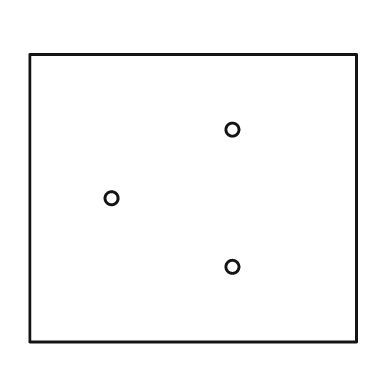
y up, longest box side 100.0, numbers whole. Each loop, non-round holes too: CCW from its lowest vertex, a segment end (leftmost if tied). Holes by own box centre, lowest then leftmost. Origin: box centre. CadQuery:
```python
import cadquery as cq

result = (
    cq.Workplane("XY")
    .moveTo(-50.0, -44.0)
    .lineTo(50.0, -44.0)
    .lineTo(50.0, 44.0)
    .lineTo(-50.0, 44.0)
    .close()
    .moveTo(12.0, -21.0)
    .circle(2.0)
    .moveTo(-25.0, 0.0)
    .circle(2.0)
    .moveTo(12.0, 21.0)
    .circle(2.0)
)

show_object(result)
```